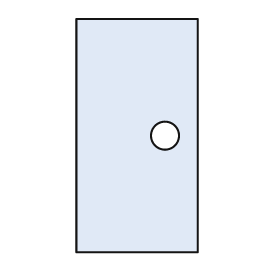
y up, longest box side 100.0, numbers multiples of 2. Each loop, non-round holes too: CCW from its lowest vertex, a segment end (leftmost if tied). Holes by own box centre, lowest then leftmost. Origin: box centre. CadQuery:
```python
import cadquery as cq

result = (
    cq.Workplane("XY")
    .moveTo(-26.0, -50.0)
    .lineTo(26.0, -50.0)
    .lineTo(26.0, 50.0)
    .lineTo(-26.0, 50.0)
    .close()
    .moveTo(12.0, 0.0)
    .circle(6.0)
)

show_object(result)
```